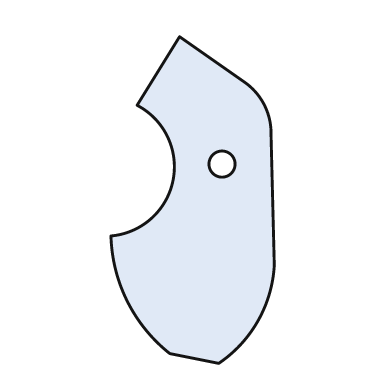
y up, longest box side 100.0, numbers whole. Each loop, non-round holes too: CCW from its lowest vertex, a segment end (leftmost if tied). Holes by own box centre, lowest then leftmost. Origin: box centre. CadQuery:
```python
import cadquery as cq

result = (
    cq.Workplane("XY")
    .moveTo(8.0, -50.0)
    .threePointArc((20.0, -37.0), (25.0, -20.0))
    .lineTo(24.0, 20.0)
    .threePointArc((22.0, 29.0), (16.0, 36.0))
    .lineTo(-4.0, 50.0)
    .lineTo(-17.0, 29.0)
    .threePointArc((-6.0, 6.0), (-25.0, -11.0))
    .threePointArc((-20.0, -31.0), (-7.0, -47.0))
    .close()
    .moveTo(9.0, 11.0)
    .circle(4.0)
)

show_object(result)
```